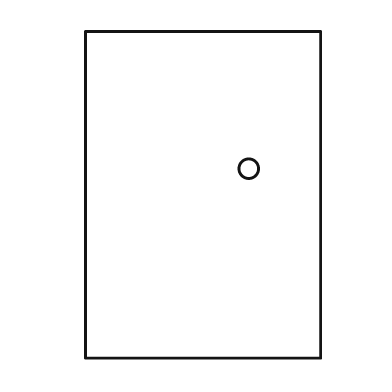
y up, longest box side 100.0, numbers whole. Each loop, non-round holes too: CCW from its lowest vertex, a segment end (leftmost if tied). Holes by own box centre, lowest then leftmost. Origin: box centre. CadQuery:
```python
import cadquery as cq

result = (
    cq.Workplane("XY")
    .moveTo(-36.0, -50.0)
    .lineTo(36.0, -50.0)
    .lineTo(36.0, 50.0)
    .lineTo(-36.0, 50.0)
    .close()
    .moveTo(14.0, 8.0)
    .circle(3.0)
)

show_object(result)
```